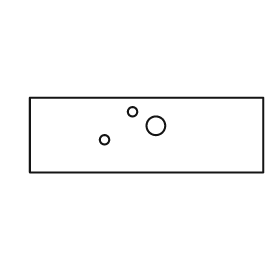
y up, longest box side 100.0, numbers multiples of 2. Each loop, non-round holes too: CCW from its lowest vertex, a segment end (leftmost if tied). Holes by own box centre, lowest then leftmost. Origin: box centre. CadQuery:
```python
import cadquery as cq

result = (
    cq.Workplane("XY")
    .moveTo(-50.0, -16.0)
    .lineTo(50.0, -16.0)
    .lineTo(50.0, 16.0)
    .lineTo(-50.0, 16.0)
    .close()
    .moveTo(-18.0, -2.0)
    .circle(2.0)
    .moveTo(4.0, 4.0)
    .circle(4.0)
    .moveTo(-6.0, 10.0)
    .circle(2.0)
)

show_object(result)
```